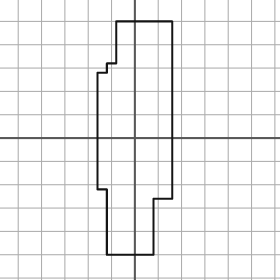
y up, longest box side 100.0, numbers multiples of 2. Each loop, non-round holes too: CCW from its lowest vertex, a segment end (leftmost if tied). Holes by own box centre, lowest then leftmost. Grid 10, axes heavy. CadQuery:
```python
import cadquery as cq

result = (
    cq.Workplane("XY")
    .moveTo(-12.0, -50.0)
    .lineTo(8.0, -50.0)
    .lineTo(8.0, -26.0)
    .lineTo(16.0, -26.0)
    .lineTo(16.0, 50.0)
    .lineTo(-8.0, 50.0)
    .lineTo(-8.0, 32.0)
    .lineTo(-12.0, 32.0)
    .lineTo(-12.0, 28.0)
    .lineTo(-16.0, 28.0)
    .lineTo(-16.0, -22.0)
    .lineTo(-12.0, -22.0)
    .close()
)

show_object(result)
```